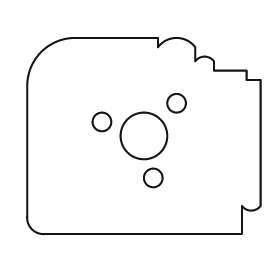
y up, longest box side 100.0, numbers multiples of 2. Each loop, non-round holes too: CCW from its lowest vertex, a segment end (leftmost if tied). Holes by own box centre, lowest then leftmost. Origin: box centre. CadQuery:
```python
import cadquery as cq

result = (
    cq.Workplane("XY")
    .moveTo(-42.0, -42.0)
    .lineTo(42.0, -42.0)
    .lineTo(42.0, -30.0)
    .threePointArc((46.0, -32.0), (50.0, -30.0))
    .lineTo(50.0, 24.0)
    .lineTo(44.0, 24.0)
    .lineTo(44.0, 28.0)
    .lineTo(30.0, 28.0)
    .lineTo(30.0, 32.0)
    .threePointArc((26.0, 34.0), (22.0, 32.0))
    .lineTo(22.0, 38.0)
    .threePointArc((14.0, 42.0), (6.0, 38.0))
    .lineTo(6.0, 42.0)
    .lineTo(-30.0, 42.0)
    .threePointArc((-44.0, 36.0), (-50.0, 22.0))
    .lineTo(-50.0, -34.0)
    .threePointArc((-48.0, -40.0), (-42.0, -42.0))
    .close()
    .moveTo(4.0, -18.0)
    .circle(4.0)
    .moveTo(0.0, 0.0)
    .circle(10.0)
    .moveTo(-18.0, 6.0)
    .circle(4.0)
    .moveTo(14.0, 14.0)
    .circle(4.0)
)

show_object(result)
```